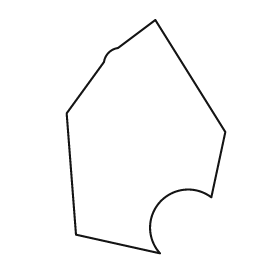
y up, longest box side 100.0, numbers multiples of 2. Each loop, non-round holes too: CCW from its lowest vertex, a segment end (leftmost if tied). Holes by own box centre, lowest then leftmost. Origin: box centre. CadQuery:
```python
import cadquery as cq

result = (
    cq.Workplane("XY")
    .moveTo(6.0, -50.0)
    .threePointArc((6.0, -28.0), (28.0, -26.0))
    .lineTo(34.0, 2.0)
    .lineTo(4.0, 50.0)
    .lineTo(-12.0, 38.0)
    .threePointArc((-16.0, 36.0), (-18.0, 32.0))
    .lineTo(-34.0, 10.0)
    .lineTo(-30.0, -42.0)
    .close()
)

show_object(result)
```